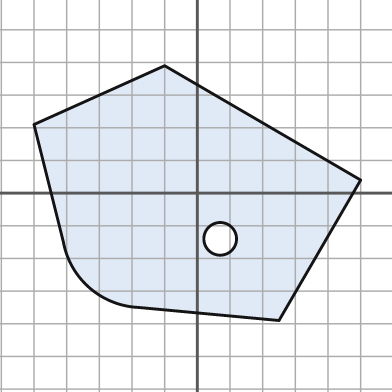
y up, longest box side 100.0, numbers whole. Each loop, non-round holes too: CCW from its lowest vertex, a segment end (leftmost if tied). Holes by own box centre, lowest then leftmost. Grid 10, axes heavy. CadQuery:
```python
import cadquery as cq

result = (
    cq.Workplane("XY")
    .moveTo(25.0, -39.0)
    .lineTo(50.0, 4.0)
    .lineTo(-10.0, 39.0)
    .lineTo(-50.0, 21.0)
    .lineTo(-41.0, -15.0)
    .threePointArc((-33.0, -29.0), (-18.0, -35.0))
    .close()
    .moveTo(7.0, -14.0)
    .circle(5.0)
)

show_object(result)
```